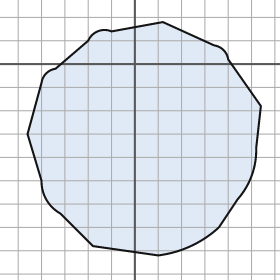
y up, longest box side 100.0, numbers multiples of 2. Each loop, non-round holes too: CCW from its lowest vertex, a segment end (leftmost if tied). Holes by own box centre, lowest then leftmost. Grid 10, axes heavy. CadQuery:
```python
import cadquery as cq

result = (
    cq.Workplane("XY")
    .moveTo(10.0, -82.0)
    .threePointArc((24.0, -78.0), (36.0, -70.0))
    .lineTo(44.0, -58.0)
    .threePointArc((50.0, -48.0), (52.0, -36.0))
    .lineTo(54.0, -18.0)
    .lineTo(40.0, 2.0)
    .threePointArc((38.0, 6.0), (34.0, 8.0))
    .lineTo(12.0, 18.0)
    .lineTo(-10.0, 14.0)
    .threePointArc((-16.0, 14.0), (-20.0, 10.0))
    .lineTo(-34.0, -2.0)
    .threePointArc((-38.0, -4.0), (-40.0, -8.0))
    .lineTo(-46.0, -30.0)
    .lineTo(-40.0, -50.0)
    .threePointArc((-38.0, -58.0), (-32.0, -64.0))
    .lineTo(-18.0, -78.0)
    .close()
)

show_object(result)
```